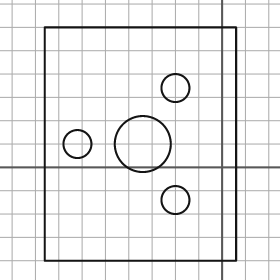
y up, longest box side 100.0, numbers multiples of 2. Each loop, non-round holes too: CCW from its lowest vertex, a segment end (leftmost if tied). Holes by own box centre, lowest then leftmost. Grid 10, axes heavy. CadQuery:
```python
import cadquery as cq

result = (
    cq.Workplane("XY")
    .moveTo(-76.0, -40.0)
    .lineTo(6.0, -40.0)
    .lineTo(6.0, 60.0)
    .lineTo(-76.0, 60.0)
    .close()
    .moveTo(-20.0, -14.0)
    .circle(6.0)
    .moveTo(-62.0, 10.0)
    .circle(6.0)
    .moveTo(-34.0, 10.0)
    .circle(12.0)
    .moveTo(-20.0, 34.0)
    .circle(6.0)
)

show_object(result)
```